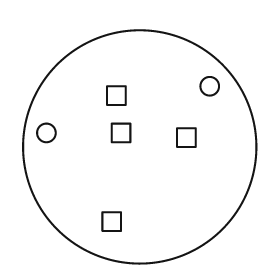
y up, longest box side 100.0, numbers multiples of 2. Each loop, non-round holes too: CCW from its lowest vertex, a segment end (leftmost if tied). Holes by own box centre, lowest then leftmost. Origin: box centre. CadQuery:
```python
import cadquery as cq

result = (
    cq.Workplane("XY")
    .moveTo(0.0, 0.0)
    .circle(50.0)
    .moveTo(-16.0, -36.0)
    .lineTo(-8.0, -36.0)
    .lineTo(-8.0, -28.0)
    .lineTo(-16.0, -28.0)
    .close()
    .moveTo(16.0, 0.0)
    .lineTo(24.0, 0.0)
    .lineTo(24.0, 8.0)
    .lineTo(16.0, 8.0)
    .close()
    .moveTo(-40.0, 6.0)
    .circle(4.0)
    .moveTo(-12.0, 2.0)
    .lineTo(-4.0, 2.0)
    .lineTo(-4.0, 10.0)
    .lineTo(-12.0, 10.0)
    .close()
    .moveTo(-14.0, 18.0)
    .lineTo(-6.0, 18.0)
    .lineTo(-6.0, 26.0)
    .lineTo(-14.0, 26.0)
    .close()
    .moveTo(30.0, 26.0)
    .circle(4.0)
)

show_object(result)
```